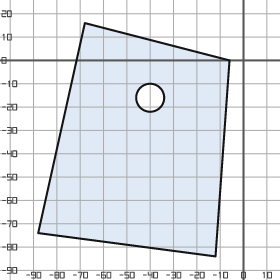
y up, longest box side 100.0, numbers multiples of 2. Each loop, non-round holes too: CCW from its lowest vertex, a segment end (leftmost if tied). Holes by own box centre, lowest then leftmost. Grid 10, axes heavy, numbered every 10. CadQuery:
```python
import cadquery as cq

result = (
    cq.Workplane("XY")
    .moveTo(-12.0, -84.0)
    .lineTo(-6.0, 0.0)
    .lineTo(-68.0, 16.0)
    .lineTo(-88.0, -74.0)
    .close()
    .moveTo(-40.0, -16.0)
    .circle(6.0)
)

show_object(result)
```